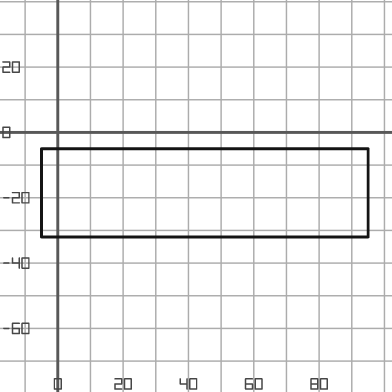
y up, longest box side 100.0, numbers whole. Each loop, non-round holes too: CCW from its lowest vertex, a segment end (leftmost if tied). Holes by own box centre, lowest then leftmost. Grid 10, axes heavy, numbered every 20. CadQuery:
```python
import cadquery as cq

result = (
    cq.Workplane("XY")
    .moveTo(-5.0, -32.0)
    .lineTo(95.0, -32.0)
    .lineTo(95.0, -5.0)
    .lineTo(-5.0, -5.0)
    .close()
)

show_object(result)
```